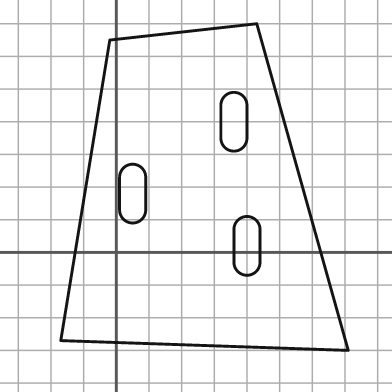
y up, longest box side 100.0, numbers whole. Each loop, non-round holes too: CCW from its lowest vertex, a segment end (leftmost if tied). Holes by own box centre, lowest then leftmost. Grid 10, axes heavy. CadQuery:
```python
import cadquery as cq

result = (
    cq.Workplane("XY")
    .moveTo(71.0, -30.0)
    .lineTo(43.0, 70.0)
    .lineTo(-2.0, 65.0)
    .lineTo(-17.0, -27.0)
    .close()
    .moveTo(36.0, -3.0)
    .threePointArc((40.0, -7.0), (44.0, -3.0))
    .lineTo(44.0, 7.0)
    .threePointArc((40.0, 11.0), (36.0, 7.0))
    .close()
    .moveTo(1.0, 13.0)
    .threePointArc((5.0, 9.0), (9.0, 13.0))
    .lineTo(9.0, 23.0)
    .threePointArc((5.0, 27.0), (1.0, 23.0))
    .close()
    .moveTo(32.0, 35.0)
    .threePointArc((36.0, 31.0), (40.0, 35.0))
    .lineTo(40.0, 45.0)
    .threePointArc((36.0, 49.0), (32.0, 45.0))
    .close()
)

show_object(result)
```